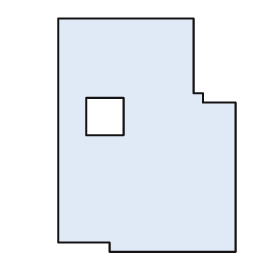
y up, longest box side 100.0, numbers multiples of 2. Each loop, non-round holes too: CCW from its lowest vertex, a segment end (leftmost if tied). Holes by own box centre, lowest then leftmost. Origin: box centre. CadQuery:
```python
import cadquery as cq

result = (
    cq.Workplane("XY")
    .moveTo(-16.0, -50.0)
    .lineTo(38.0, -50.0)
    .lineTo(38.0, 14.0)
    .lineTo(24.0, 14.0)
    .lineTo(24.0, 18.0)
    .lineTo(20.0, 18.0)
    .lineTo(20.0, 50.0)
    .lineTo(-38.0, 50.0)
    .lineTo(-38.0, -46.0)
    .lineTo(-16.0, -46.0)
    .close()
    .moveTo(-26.0, 0.0)
    .lineTo(-10.0, 0.0)
    .lineTo(-10.0, 16.0)
    .lineTo(-26.0, 16.0)
    .close()
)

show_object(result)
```